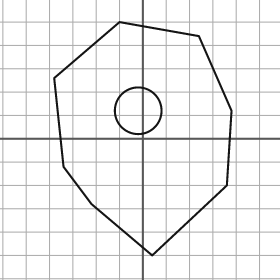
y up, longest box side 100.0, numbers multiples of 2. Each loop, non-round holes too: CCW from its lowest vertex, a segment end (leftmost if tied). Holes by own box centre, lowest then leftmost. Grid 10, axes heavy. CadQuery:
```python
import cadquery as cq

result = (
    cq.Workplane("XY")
    .moveTo(4.0, -50.0)
    .lineTo(36.0, -20.0)
    .lineTo(38.0, 12.0)
    .lineTo(24.0, 44.0)
    .lineTo(-10.0, 50.0)
    .lineTo(-38.0, 26.0)
    .lineTo(-34.0, -12.0)
    .lineTo(-22.0, -28.0)
    .close()
    .moveTo(-2.0, 12.0)
    .circle(10.0)
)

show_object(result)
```